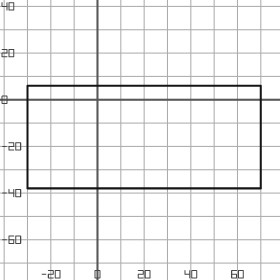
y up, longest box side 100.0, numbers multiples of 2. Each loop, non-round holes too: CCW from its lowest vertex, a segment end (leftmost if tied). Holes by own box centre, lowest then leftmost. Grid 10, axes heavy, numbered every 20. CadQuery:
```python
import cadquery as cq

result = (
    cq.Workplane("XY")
    .moveTo(-30.0, -38.0)
    .lineTo(70.0, -38.0)
    .lineTo(70.0, 6.0)
    .lineTo(-30.0, 6.0)
    .close()
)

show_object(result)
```